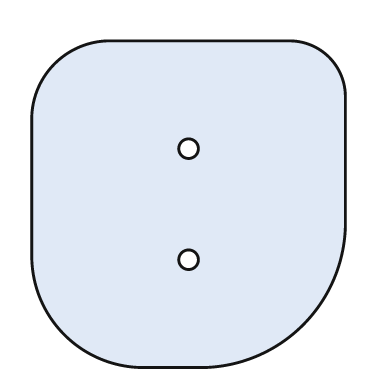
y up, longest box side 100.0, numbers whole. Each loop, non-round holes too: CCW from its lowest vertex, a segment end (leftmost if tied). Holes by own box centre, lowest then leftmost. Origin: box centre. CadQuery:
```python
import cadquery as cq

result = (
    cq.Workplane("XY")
    .moveTo(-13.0, -50.0)
    .lineTo(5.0, -50.0)
    .threePointArc((35.0, -37.0), (48.0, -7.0))
    .lineTo(48.0, 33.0)
    .threePointArc((43.0, 45.0), (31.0, 50.0))
    .lineTo(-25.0, 50.0)
    .threePointArc((-41.0, 43.0), (-48.0, 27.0))
    .lineTo(-48.0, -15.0)
    .threePointArc((-38.0, -40.0), (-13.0, -50.0))
    .close()
    .moveTo(0.0, -17.0)
    .circle(3.0)
    .moveTo(0.0, 17.0)
    .circle(3.0)
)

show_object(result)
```